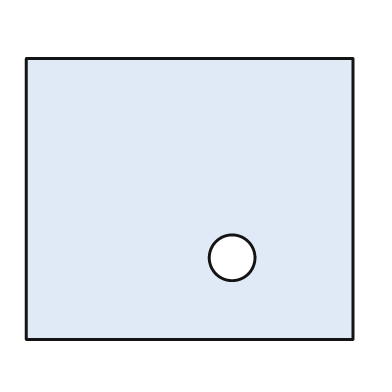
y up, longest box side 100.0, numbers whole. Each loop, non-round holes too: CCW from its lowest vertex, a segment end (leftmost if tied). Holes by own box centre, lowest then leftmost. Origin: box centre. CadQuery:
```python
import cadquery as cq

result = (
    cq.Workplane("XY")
    .moveTo(-50.0, -43.0)
    .lineTo(50.0, -43.0)
    .lineTo(50.0, 43.0)
    .lineTo(-50.0, 43.0)
    .close()
    .moveTo(13.0, -18.0)
    .circle(7.0)
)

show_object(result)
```